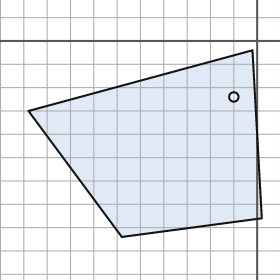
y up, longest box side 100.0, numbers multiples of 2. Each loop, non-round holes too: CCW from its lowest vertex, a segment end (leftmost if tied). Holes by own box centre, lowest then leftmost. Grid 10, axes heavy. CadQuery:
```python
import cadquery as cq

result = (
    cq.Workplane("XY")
    .moveTo(-58.0, -84.0)
    .lineTo(2.0, -76.0)
    .lineTo(-2.0, -4.0)
    .lineTo(-98.0, -30.0)
    .close()
    .moveTo(-10.0, -24.0)
    .circle(2.0)
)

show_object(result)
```